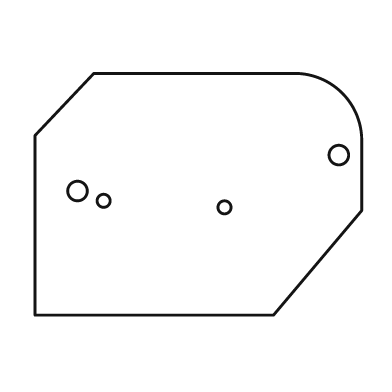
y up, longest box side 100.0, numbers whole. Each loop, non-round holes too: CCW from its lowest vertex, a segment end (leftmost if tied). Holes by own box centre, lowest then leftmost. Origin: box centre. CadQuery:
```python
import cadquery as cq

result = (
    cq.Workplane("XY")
    .moveTo(-50.0, -37.0)
    .lineTo(23.0, -37.0)
    .lineTo(50.0, -5.0)
    .lineTo(50.0, 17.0)
    .threePointArc((44.0, 31.0), (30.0, 37.0))
    .lineTo(-32.0, 37.0)
    .lineTo(-50.0, 18.0)
    .close()
    .moveTo(8.0, -4.0)
    .circle(2.0)
    .moveTo(-29.0, -2.0)
    .circle(2.0)
    .moveTo(-37.0, 1.0)
    .circle(3.0)
    .moveTo(43.0, 12.0)
    .circle(3.0)
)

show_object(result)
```